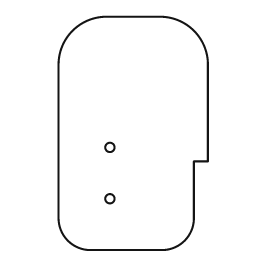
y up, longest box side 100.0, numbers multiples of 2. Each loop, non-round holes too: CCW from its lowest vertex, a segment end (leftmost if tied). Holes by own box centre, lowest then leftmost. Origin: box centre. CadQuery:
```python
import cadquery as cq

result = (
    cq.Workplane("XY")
    .moveTo(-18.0, -50.0)
    .lineTo(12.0, -50.0)
    .threePointArc((22.0, -46.0), (26.0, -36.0))
    .lineTo(26.0, -12.0)
    .lineTo(32.0, -12.0)
    .lineTo(32.0, 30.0)
    .threePointArc((26.0, 44.0), (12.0, 50.0))
    .lineTo(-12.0, 50.0)
    .threePointArc((-26.0, 44.0), (-32.0, 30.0))
    .lineTo(-32.0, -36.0)
    .threePointArc((-28.0, -46.0), (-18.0, -50.0))
    .close()
    .moveTo(-10.0, -28.0)
    .circle(2.0)
    .moveTo(-10.0, -6.0)
    .circle(2.0)
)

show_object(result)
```